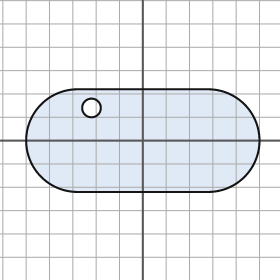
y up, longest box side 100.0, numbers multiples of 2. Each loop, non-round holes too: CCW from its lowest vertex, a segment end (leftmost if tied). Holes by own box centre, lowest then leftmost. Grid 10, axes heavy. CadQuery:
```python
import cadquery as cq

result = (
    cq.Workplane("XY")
    .moveTo(-28.0, -22.0)
    .lineTo(28.0, -22.0)
    .threePointArc((50.0, 0.0), (28.0, 22.0))
    .lineTo(-28.0, 22.0)
    .threePointArc((-50.0, 0.0), (-28.0, -22.0))
    .close()
    .moveTo(-22.0, 14.0)
    .circle(4.0)
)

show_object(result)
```